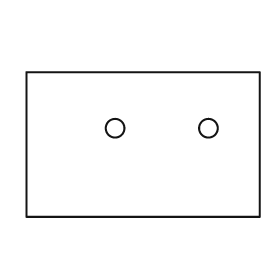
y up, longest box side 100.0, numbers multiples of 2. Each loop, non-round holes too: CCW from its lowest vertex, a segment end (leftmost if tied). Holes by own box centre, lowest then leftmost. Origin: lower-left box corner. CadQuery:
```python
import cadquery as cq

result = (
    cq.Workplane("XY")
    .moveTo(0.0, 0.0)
    .lineTo(100.0, 0.0)
    .lineTo(100.0, 62.0)
    .lineTo(0.0, 62.0)
    .close()
    .moveTo(38.0, 38.0)
    .circle(4.0)
    .moveTo(78.0, 38.0)
    .circle(4.0)
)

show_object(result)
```